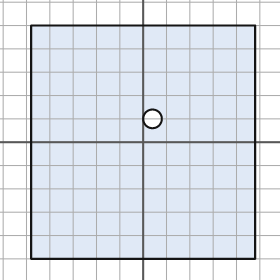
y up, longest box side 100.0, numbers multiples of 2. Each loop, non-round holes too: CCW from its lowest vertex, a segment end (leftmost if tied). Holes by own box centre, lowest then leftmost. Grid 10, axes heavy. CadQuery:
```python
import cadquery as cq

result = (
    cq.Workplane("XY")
    .moveTo(-48.0, -50.0)
    .lineTo(48.0, -50.0)
    .lineTo(48.0, 50.0)
    .lineTo(-48.0, 50.0)
    .close()
    .moveTo(4.0, 10.0)
    .circle(4.0)
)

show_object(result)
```